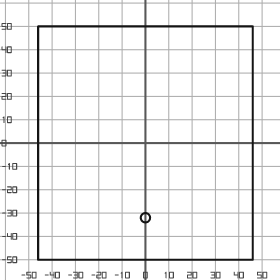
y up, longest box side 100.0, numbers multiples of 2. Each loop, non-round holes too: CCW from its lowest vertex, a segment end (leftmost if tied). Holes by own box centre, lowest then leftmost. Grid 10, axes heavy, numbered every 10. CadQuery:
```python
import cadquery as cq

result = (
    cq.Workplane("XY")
    .moveTo(-46.0, -50.0)
    .lineTo(46.0, -50.0)
    .lineTo(46.0, 50.0)
    .lineTo(-46.0, 50.0)
    .close()
    .moveTo(0.0, -32.0)
    .circle(2.0)
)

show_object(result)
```